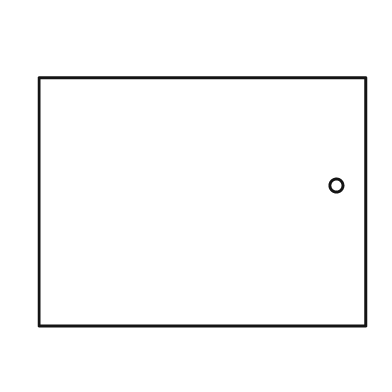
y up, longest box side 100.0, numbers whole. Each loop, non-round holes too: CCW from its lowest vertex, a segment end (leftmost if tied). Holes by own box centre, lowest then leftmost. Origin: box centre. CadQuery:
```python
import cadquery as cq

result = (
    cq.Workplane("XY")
    .moveTo(-50.0, -38.0)
    .lineTo(50.0, -38.0)
    .lineTo(50.0, 38.0)
    .lineTo(-50.0, 38.0)
    .close()
    .moveTo(41.0, 5.0)
    .circle(2.0)
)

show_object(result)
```